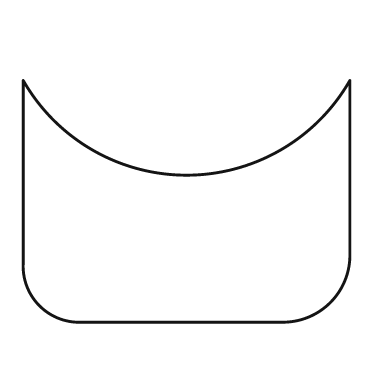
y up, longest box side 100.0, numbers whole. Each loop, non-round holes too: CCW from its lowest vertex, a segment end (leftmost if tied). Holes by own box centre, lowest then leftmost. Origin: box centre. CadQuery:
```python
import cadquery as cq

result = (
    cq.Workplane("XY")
    .moveTo(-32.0, -37.0)
    .lineTo(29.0, -37.0)
    .threePointArc((44.0, -31.0), (50.0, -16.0))
    .lineTo(50.0, 37.0)
    .threePointArc((0.0, 8.0), (-50.0, 37.0))
    .lineTo(-50.0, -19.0)
    .threePointArc((-45.0, -32.0), (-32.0, -37.0))
    .close()
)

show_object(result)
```